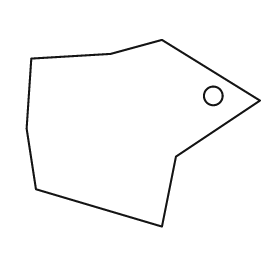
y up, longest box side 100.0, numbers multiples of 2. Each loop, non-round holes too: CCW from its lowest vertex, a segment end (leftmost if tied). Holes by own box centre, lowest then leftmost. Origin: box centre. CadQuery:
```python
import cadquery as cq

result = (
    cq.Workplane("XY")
    .moveTo(8.0, -40.0)
    .lineTo(14.0, -10.0)
    .lineTo(50.0, 14.0)
    .lineTo(8.0, 40.0)
    .lineTo(-14.0, 34.0)
    .lineTo(-48.0, 32.0)
    .lineTo(-50.0, 2.0)
    .lineTo(-46.0, -24.0)
    .close()
    .moveTo(30.0, 16.0)
    .circle(4.0)
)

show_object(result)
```